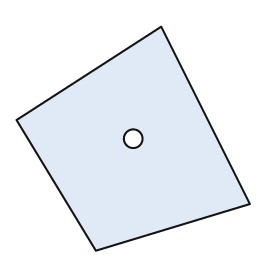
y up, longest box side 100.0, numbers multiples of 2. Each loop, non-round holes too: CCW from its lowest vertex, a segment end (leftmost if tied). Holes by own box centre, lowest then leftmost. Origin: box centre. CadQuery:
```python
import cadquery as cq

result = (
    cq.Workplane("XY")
    .moveTo(-16.0, -48.0)
    .lineTo(50.0, -28.0)
    .lineTo(12.0, 48.0)
    .lineTo(-50.0, 8.0)
    .close()
    .moveTo(0.0, 0.0)
    .circle(4.0)
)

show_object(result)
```